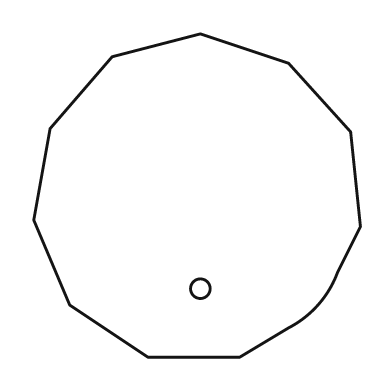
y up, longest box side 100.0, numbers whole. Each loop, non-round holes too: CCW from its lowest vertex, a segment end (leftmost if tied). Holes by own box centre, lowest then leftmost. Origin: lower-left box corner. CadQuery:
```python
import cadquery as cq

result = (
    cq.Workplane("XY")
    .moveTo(35.0, 0.0)
    .lineTo(63.0, 0.0)
    .lineTo(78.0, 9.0)
    .threePointArc((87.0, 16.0), (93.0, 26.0))
    .lineTo(100.0, 40.0)
    .lineTo(97.0, 69.0)
    .lineTo(78.0, 90.0)
    .lineTo(51.0, 99.0)
    .lineTo(24.0, 92.0)
    .lineTo(5.0, 70.0)
    .lineTo(0.0, 42.0)
    .lineTo(11.0, 16.0)
    .close()
    .moveTo(51.0, 21.0)
    .circle(3.0)
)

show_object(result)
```